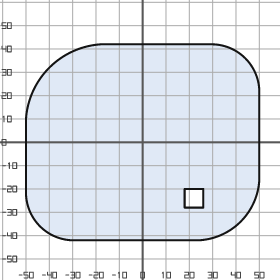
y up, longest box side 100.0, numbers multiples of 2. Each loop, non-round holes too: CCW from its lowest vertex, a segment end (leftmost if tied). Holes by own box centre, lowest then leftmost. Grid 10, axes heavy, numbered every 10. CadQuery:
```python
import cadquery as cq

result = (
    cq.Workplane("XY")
    .moveTo(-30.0, -42.0)
    .lineTo(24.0, -42.0)
    .threePointArc((42.0, -34.0), (50.0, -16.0))
    .lineTo(50.0, 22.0)
    .threePointArc((44.0, 36.0), (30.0, 42.0))
    .lineTo(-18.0, 42.0)
    .threePointArc((-40.0, 32.0), (-50.0, 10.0))
    .lineTo(-50.0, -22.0)
    .threePointArc((-44.0, -36.0), (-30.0, -42.0))
    .close()
    .moveTo(18.0, -28.0)
    .lineTo(26.0, -28.0)
    .lineTo(26.0, -20.0)
    .lineTo(18.0, -20.0)
    .close()
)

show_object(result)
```